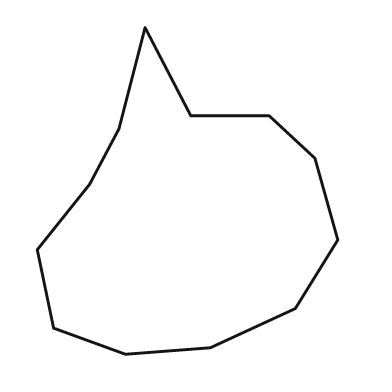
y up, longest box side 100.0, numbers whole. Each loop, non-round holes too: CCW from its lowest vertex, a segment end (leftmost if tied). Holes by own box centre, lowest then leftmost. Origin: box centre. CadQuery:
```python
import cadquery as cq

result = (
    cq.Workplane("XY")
    .moveTo(-19.0, -50.0)
    .lineTo(7.0, -48.0)
    .lineTo(33.0, -36.0)
    .lineTo(46.0, -15.0)
    .lineTo(39.0, 10.0)
    .lineTo(25.0, 23.0)
    .lineTo(1.0, 23.0)
    .lineTo(-13.0, 50.0)
    .lineTo(-21.0, 19.0)
    .lineTo(-30.0, 2.0)
    .lineTo(-46.0, -18.0)
    .lineTo(-41.0, -42.0)
    .close()
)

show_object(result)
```